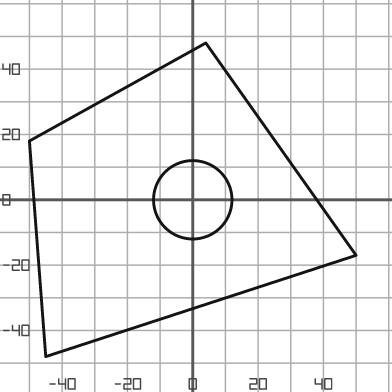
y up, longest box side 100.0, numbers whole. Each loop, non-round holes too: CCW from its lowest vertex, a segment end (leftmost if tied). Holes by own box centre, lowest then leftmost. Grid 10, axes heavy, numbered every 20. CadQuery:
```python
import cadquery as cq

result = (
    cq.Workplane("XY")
    .moveTo(-45.0, -48.0)
    .lineTo(50.0, -17.0)
    .lineTo(4.0, 48.0)
    .lineTo(-50.0, 18.0)
    .close()
    .moveTo(0.0, 0.0)
    .circle(12.0)
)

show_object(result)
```